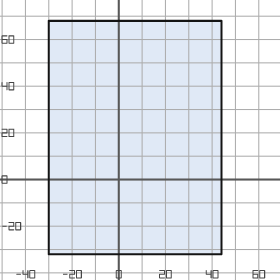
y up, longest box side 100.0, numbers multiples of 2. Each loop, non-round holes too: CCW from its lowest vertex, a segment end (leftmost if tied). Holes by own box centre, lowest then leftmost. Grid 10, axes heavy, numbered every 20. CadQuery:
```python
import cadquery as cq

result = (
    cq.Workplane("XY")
    .moveTo(-30.0, -32.0)
    .lineTo(44.0, -32.0)
    .lineTo(44.0, 68.0)
    .lineTo(-30.0, 68.0)
    .close()
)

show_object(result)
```